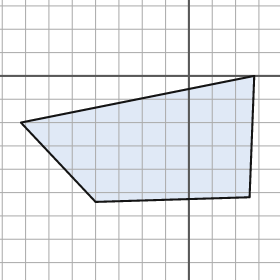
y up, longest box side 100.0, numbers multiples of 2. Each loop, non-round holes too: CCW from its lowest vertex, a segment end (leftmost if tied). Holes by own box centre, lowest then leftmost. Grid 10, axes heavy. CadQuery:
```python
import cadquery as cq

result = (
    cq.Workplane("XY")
    .moveTo(-40.0, -54.0)
    .lineTo(26.0, -52.0)
    .lineTo(28.0, 0.0)
    .lineTo(-72.0, -20.0)
    .close()
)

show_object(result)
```